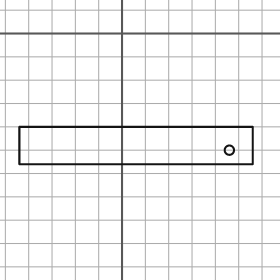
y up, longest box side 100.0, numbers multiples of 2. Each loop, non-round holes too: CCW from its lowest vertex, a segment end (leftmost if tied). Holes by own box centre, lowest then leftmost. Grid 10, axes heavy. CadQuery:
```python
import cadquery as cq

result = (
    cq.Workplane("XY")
    .moveTo(-44.0, -56.0)
    .lineTo(56.0, -56.0)
    .lineTo(56.0, -40.0)
    .lineTo(-44.0, -40.0)
    .close()
    .moveTo(46.0, -50.0)
    .circle(2.0)
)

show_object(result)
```